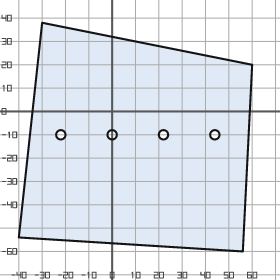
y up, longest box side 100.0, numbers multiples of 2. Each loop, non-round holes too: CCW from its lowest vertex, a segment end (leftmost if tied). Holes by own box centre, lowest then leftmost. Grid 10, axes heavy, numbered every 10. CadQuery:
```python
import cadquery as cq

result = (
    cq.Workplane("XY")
    .moveTo(56.0, -60.0)
    .lineTo(60.0, 20.0)
    .lineTo(-30.0, 38.0)
    .lineTo(-40.0, -54.0)
    .close()
    .moveTo(-22.0, -10.0)
    .circle(2.0)
    .moveTo(0.0, -10.0)
    .circle(2.0)
    .moveTo(22.0, -10.0)
    .circle(2.0)
    .moveTo(44.0, -10.0)
    .circle(2.0)
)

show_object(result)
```